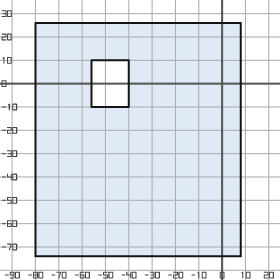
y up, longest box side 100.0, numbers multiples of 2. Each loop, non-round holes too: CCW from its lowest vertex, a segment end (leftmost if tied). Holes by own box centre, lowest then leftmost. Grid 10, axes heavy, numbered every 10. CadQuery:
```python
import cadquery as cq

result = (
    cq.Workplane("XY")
    .moveTo(-80.0, -74.0)
    .lineTo(8.0, -74.0)
    .lineTo(8.0, 26.0)
    .lineTo(-80.0, 26.0)
    .close()
    .moveTo(-56.0, -10.0)
    .lineTo(-40.0, -10.0)
    .lineTo(-40.0, 10.0)
    .lineTo(-56.0, 10.0)
    .close()
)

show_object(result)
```